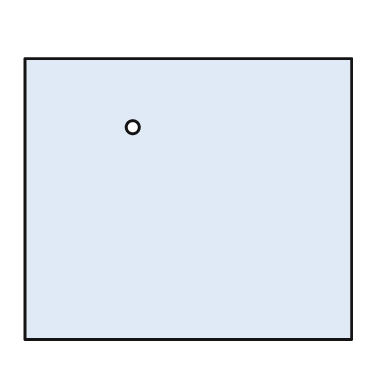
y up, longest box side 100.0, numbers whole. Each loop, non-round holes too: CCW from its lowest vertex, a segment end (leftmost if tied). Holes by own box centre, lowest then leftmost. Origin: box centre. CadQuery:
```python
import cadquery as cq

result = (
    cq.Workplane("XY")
    .moveTo(-50.0, -43.0)
    .lineTo(50.0, -43.0)
    .lineTo(50.0, 43.0)
    .lineTo(-50.0, 43.0)
    .close()
    .moveTo(-17.0, 22.0)
    .circle(2.0)
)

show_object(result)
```